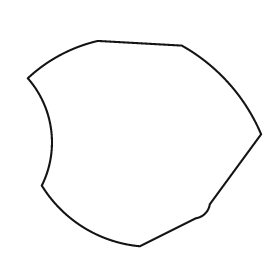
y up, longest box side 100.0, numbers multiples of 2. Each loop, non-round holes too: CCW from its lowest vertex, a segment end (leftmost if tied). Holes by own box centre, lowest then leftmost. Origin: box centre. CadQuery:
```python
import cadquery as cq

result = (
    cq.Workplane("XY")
    .moveTo(-2.0, -44.0)
    .lineTo(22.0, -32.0)
    .threePointArc((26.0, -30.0), (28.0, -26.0))
    .lineTo(50.0, 4.0)
    .threePointArc((36.0, 26.0), (16.0, 42.0))
    .lineTo(-20.0, 44.0)
    .threePointArc((-36.0, 38.0), (-50.0, 28.0))
    .threePointArc((-40.0, 6.0), (-44.0, -18.0))
    .threePointArc((-26.0, -36.0), (-2.0, -44.0))
    .close()
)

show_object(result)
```